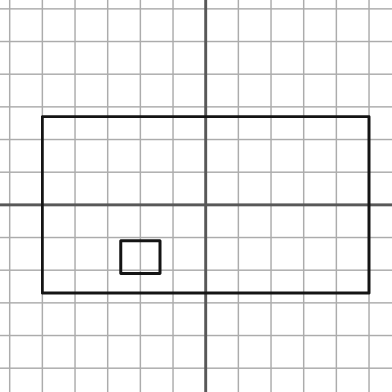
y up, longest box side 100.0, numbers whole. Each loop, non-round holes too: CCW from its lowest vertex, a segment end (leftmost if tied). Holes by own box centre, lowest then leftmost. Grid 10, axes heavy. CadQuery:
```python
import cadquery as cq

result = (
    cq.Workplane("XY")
    .moveTo(-50.0, -27.0)
    .lineTo(50.0, -27.0)
    .lineTo(50.0, 27.0)
    .lineTo(-50.0, 27.0)
    .close()
    .moveTo(-26.0, -21.0)
    .lineTo(-14.0, -21.0)
    .lineTo(-14.0, -11.0)
    .lineTo(-26.0, -11.0)
    .close()
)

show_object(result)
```